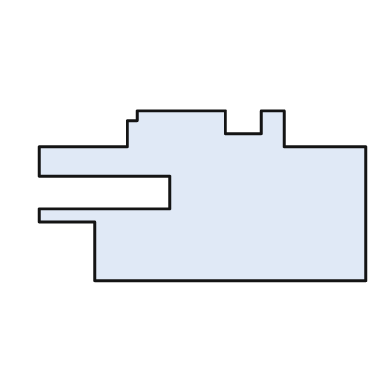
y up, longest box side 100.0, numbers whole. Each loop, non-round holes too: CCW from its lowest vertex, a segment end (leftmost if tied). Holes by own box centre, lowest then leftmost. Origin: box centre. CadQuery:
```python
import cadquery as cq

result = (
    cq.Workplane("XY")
    .moveTo(-33.0, -26.0)
    .lineTo(50.0, -26.0)
    .lineTo(50.0, 15.0)
    .lineTo(25.0, 15.0)
    .lineTo(25.0, 26.0)
    .lineTo(18.0, 26.0)
    .lineTo(18.0, 19.0)
    .lineTo(7.0, 19.0)
    .lineTo(7.0, 26.0)
    .lineTo(-20.0, 26.0)
    .lineTo(-20.0, 23.0)
    .lineTo(-23.0, 23.0)
    .lineTo(-23.0, 15.0)
    .lineTo(-50.0, 15.0)
    .lineTo(-50.0, 6.0)
    .lineTo(-10.0, 6.0)
    .lineTo(-10.0, -4.0)
    .lineTo(-50.0, -4.0)
    .lineTo(-50.0, -8.0)
    .lineTo(-33.0, -8.0)
    .close()
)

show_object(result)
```